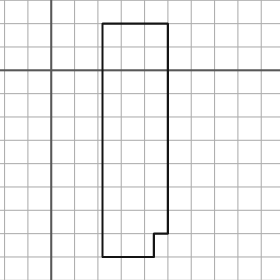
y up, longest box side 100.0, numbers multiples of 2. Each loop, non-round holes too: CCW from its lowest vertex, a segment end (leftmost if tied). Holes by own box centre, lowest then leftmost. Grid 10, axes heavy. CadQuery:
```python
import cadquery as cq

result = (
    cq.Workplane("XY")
    .moveTo(22.0, -80.0)
    .lineTo(44.0, -80.0)
    .lineTo(44.0, -70.0)
    .lineTo(50.0, -70.0)
    .lineTo(50.0, 20.0)
    .lineTo(22.0, 20.0)
    .close()
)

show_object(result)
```